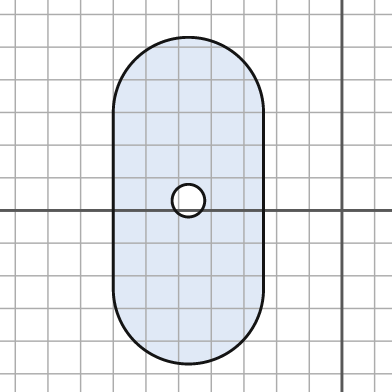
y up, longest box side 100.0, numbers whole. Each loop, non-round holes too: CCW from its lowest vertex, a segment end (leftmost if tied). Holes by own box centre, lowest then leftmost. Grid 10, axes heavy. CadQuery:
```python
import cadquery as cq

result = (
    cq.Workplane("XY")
    .moveTo(-70.0, -24.0)
    .threePointArc((-47.0, -47.0), (-24.0, -24.0))
    .lineTo(-24.0, 30.0)
    .threePointArc((-47.0, 53.0), (-70.0, 30.0))
    .close()
    .moveTo(-47.0, 3.0)
    .circle(5.0)
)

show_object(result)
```